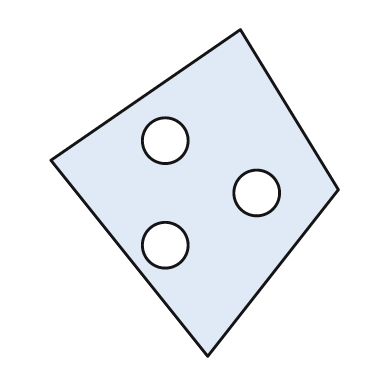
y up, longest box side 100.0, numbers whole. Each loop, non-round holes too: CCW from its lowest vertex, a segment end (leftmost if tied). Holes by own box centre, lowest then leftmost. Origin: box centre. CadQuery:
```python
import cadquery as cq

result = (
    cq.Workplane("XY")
    .moveTo(4.0, -50.0)
    .lineTo(44.0, 1.0)
    .lineTo(14.0, 50.0)
    .lineTo(-44.0, 10.0)
    .close()
    .moveTo(-9.0, -16.0)
    .circle(7.0)
    .moveTo(19.0, 0.0)
    .circle(7.0)
    .moveTo(-9.0, 16.0)
    .circle(7.0)
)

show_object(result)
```